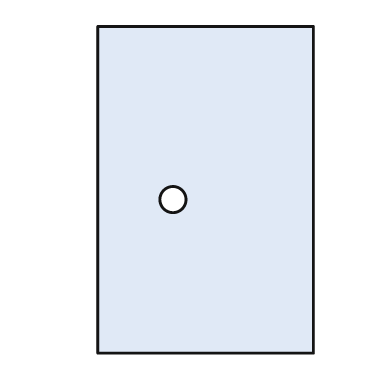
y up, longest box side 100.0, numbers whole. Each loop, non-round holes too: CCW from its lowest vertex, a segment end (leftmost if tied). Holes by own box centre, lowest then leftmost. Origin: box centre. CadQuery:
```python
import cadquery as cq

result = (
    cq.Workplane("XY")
    .moveTo(-33.0, -50.0)
    .lineTo(33.0, -50.0)
    .lineTo(33.0, 50.0)
    .lineTo(-33.0, 50.0)
    .close()
    .moveTo(-10.0, -3.0)
    .circle(4.0)
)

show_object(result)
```